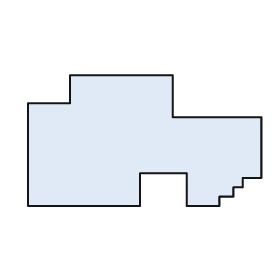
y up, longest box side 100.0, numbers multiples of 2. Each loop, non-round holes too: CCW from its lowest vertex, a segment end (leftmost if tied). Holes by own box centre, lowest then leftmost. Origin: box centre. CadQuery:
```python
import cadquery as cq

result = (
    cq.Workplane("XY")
    .moveTo(-50.0, -28.0)
    .lineTo(-2.0, -28.0)
    .lineTo(-2.0, -14.0)
    .lineTo(18.0, -14.0)
    .lineTo(18.0, -28.0)
    .lineTo(32.0, -28.0)
    .lineTo(32.0, -24.0)
    .lineTo(38.0, -24.0)
    .lineTo(38.0, -20.0)
    .lineTo(42.0, -20.0)
    .lineTo(42.0, -16.0)
    .lineTo(50.0, -16.0)
    .lineTo(50.0, 10.0)
    .lineTo(12.0, 10.0)
    .lineTo(12.0, 28.0)
    .lineTo(-32.0, 28.0)
    .lineTo(-32.0, 16.0)
    .lineTo(-50.0, 16.0)
    .close()
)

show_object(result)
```